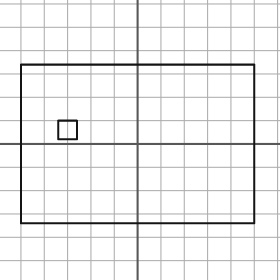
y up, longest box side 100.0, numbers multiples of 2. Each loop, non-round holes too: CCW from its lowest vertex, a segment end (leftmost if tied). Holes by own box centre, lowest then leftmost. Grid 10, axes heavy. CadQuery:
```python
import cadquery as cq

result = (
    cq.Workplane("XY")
    .moveTo(-50.0, -34.0)
    .lineTo(50.0, -34.0)
    .lineTo(50.0, 34.0)
    .lineTo(-50.0, 34.0)
    .close()
    .moveTo(-34.0, 2.0)
    .lineTo(-26.0, 2.0)
    .lineTo(-26.0, 10.0)
    .lineTo(-34.0, 10.0)
    .close()
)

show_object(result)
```